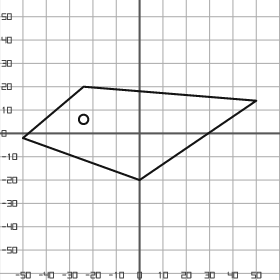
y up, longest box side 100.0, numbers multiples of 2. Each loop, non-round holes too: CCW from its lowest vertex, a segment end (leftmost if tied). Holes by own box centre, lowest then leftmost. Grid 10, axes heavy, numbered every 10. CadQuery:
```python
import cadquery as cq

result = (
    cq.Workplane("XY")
    .moveTo(0.0, -20.0)
    .lineTo(50.0, 14.0)
    .lineTo(-24.0, 20.0)
    .lineTo(-50.0, -2.0)
    .close()
    .moveTo(-24.0, 6.0)
    .circle(2.0)
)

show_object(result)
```